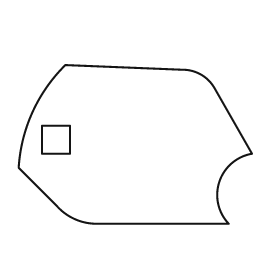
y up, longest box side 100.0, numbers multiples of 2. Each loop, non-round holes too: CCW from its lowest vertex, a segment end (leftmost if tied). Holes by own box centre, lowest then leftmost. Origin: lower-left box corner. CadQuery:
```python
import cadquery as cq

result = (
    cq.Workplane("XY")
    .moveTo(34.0, 0.0)
    .lineTo(90.0, 0.0)
    .threePointArc((86.0, 18.0), (100.0, 30.0))
    .lineTo(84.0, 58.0)
    .threePointArc((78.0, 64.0), (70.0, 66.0))
    .lineTo(20.0, 68.0)
    .threePointArc((6.0, 48.0), (0.0, 24.0))
    .lineTo(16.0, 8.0)
    .threePointArc((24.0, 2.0), (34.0, 0.0))
    .close()
    .moveTo(10.0, 30.0)
    .lineTo(22.0, 30.0)
    .lineTo(22.0, 42.0)
    .lineTo(10.0, 42.0)
    .close()
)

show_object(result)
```